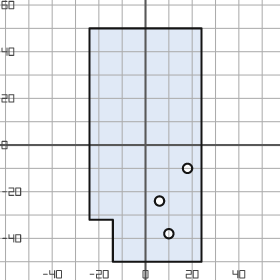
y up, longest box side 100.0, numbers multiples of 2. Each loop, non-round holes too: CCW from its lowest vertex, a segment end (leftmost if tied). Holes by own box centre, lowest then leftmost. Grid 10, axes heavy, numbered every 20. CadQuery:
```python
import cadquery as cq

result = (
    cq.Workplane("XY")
    .moveTo(-14.0, -50.0)
    .lineTo(24.0, -50.0)
    .lineTo(24.0, 50.0)
    .lineTo(-24.0, 50.0)
    .lineTo(-24.0, -32.0)
    .lineTo(-14.0, -32.0)
    .close()
    .moveTo(10.0, -38.0)
    .circle(2.0)
    .moveTo(6.0, -24.0)
    .circle(2.0)
    .moveTo(18.0, -10.0)
    .circle(2.0)
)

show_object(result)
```